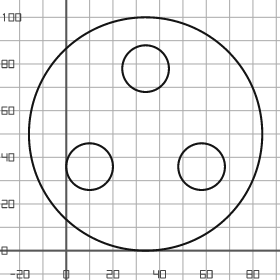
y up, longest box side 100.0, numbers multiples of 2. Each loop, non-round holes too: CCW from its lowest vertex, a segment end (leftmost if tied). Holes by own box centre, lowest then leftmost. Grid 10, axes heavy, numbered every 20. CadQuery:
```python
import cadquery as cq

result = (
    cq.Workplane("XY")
    .moveTo(34.0, 50.0)
    .circle(50.0)
    .moveTo(10.0, 36.0)
    .circle(10.0)
    .moveTo(58.0, 36.0)
    .circle(10.0)
    .moveTo(34.0, 78.0)
    .circle(10.0)
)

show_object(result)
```